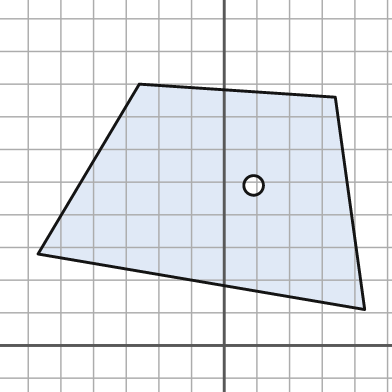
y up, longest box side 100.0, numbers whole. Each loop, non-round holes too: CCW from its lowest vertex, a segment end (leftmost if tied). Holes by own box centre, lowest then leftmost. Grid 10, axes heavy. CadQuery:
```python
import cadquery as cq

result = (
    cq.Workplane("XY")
    .moveTo(43.0, 11.0)
    .lineTo(34.0, 76.0)
    .lineTo(-26.0, 80.0)
    .lineTo(-57.0, 28.0)
    .close()
    .moveTo(9.0, 49.0)
    .circle(3.0)
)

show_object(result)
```